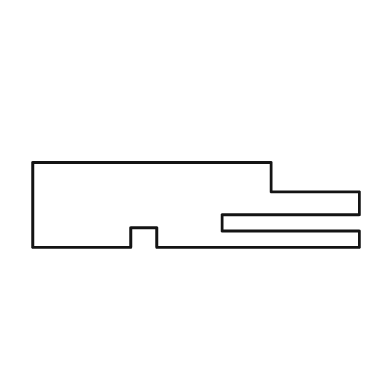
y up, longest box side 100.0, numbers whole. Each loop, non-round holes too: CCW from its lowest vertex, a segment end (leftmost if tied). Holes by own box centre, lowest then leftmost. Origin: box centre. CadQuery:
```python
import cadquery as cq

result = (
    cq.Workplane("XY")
    .moveTo(-50.0, -13.0)
    .lineTo(-20.0, -13.0)
    .lineTo(-20.0, -7.0)
    .lineTo(-12.0, -7.0)
    .lineTo(-12.0, -13.0)
    .lineTo(50.0, -13.0)
    .lineTo(50.0, -8.0)
    .lineTo(8.0, -8.0)
    .lineTo(8.0, -3.0)
    .lineTo(50.0, -3.0)
    .lineTo(50.0, 4.0)
    .lineTo(23.0, 4.0)
    .lineTo(23.0, 13.0)
    .lineTo(-50.0, 13.0)
    .close()
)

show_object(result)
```